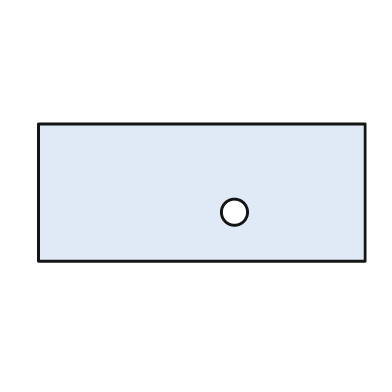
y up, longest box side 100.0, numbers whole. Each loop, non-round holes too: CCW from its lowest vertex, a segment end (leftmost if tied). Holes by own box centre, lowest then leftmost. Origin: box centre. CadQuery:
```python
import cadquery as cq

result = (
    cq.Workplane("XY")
    .moveTo(-50.0, -21.0)
    .lineTo(50.0, -21.0)
    .lineTo(50.0, 21.0)
    .lineTo(-50.0, 21.0)
    .close()
    .moveTo(10.0, -6.0)
    .circle(4.0)
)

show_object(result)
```